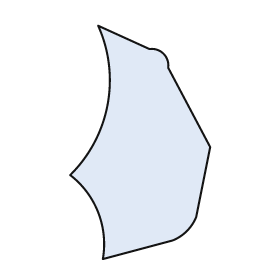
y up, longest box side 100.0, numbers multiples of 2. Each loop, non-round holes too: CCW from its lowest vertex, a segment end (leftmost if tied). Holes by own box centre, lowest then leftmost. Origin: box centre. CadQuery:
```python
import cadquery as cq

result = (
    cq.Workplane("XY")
    .moveTo(-16.0, -50.0)
    .lineTo(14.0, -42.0)
    .threePointArc((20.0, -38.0), (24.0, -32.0))
    .lineTo(30.0, -2.0)
    .lineTo(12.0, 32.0)
    .threePointArc((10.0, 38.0), (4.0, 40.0))
    .lineTo(-18.0, 50.0)
    .threePointArc((-14.0, 16.0), (-30.0, -14.0))
    .threePointArc((-18.0, -30.0), (-16.0, -50.0))
    .close()
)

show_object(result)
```